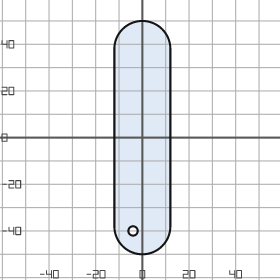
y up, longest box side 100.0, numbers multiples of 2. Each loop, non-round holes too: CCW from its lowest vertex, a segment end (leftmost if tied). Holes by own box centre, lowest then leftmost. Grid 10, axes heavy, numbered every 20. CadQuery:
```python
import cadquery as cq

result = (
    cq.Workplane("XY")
    .moveTo(-12.0, -38.0)
    .threePointArc((0.0, -50.0), (12.0, -38.0))
    .lineTo(12.0, 38.0)
    .threePointArc((0.0, 50.0), (-12.0, 38.0))
    .close()
    .moveTo(-4.0, -40.0)
    .circle(2.0)
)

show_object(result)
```